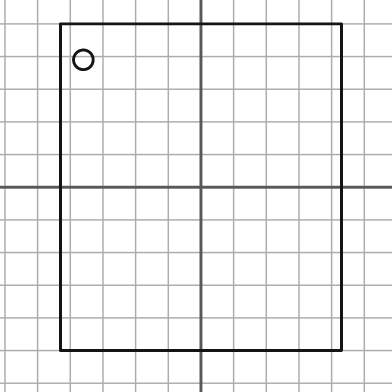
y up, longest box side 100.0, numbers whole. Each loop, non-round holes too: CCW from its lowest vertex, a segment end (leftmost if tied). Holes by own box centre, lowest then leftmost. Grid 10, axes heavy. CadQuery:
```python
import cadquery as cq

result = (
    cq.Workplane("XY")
    .moveTo(-43.0, -50.0)
    .lineTo(43.0, -50.0)
    .lineTo(43.0, 50.0)
    .lineTo(-43.0, 50.0)
    .close()
    .moveTo(-36.0, 39.0)
    .circle(3.0)
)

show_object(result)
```